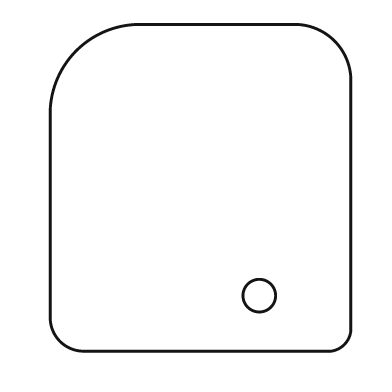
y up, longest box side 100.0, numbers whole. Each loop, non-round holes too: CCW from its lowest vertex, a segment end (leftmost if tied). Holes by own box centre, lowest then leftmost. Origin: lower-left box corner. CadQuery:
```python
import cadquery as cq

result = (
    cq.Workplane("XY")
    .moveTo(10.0, 0.0)
    .lineTo(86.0, 0.0)
    .threePointArc((90.0, 2.0), (92.0, 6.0))
    .lineTo(92.0, 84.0)
    .threePointArc((87.0, 95.0), (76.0, 100.0))
    .lineTo(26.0, 100.0)
    .threePointArc((8.0, 92.0), (0.0, 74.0))
    .lineTo(0.0, 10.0)
    .threePointArc((3.0, 3.0), (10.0, 0.0))
    .close()
    .moveTo(64.0, 17.0)
    .circle(5.0)
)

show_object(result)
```